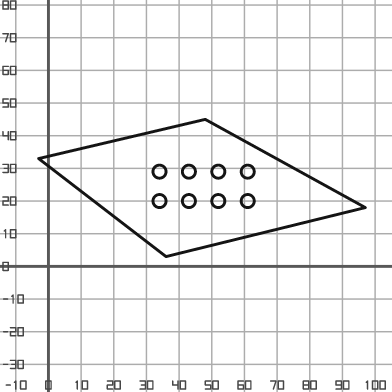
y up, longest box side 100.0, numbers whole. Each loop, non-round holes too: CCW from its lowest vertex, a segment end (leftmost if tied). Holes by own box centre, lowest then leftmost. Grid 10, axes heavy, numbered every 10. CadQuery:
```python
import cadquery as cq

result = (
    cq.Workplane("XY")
    .moveTo(36.0, 3.0)
    .lineTo(97.0, 18.0)
    .lineTo(48.0, 45.0)
    .lineTo(-3.0, 33.0)
    .close()
    .moveTo(34.0, 20.0)
    .circle(2.0)
    .moveTo(43.0, 20.0)
    .circle(2.0)
    .moveTo(52.0, 20.0)
    .circle(2.0)
    .moveTo(61.0, 20.0)
    .circle(2.0)
    .moveTo(34.0, 29.0)
    .circle(2.0)
    .moveTo(43.0, 29.0)
    .circle(2.0)
    .moveTo(52.0, 29.0)
    .circle(2.0)
    .moveTo(61.0, 29.0)
    .circle(2.0)
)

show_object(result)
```